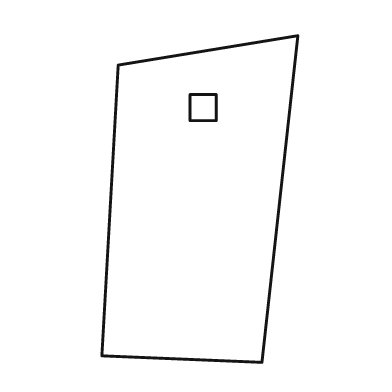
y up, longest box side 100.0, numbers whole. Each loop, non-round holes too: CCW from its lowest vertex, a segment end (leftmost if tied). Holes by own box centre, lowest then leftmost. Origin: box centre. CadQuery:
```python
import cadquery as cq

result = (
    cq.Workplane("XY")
    .moveTo(19.0, -50.0)
    .lineTo(30.0, 50.0)
    .lineTo(-25.0, 41.0)
    .lineTo(-30.0, -48.0)
    .close()
    .moveTo(-3.0, 24.0)
    .lineTo(5.0, 24.0)
    .lineTo(5.0, 32.0)
    .lineTo(-3.0, 32.0)
    .close()
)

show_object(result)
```